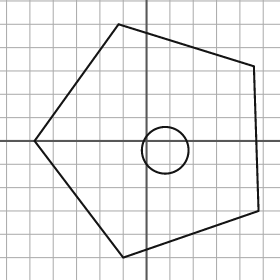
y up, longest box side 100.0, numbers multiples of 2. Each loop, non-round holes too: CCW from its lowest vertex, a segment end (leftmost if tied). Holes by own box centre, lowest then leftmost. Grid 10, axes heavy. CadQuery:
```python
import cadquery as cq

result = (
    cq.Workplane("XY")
    .moveTo(-10.0, -50.0)
    .lineTo(48.0, -30.0)
    .lineTo(46.0, 32.0)
    .lineTo(-12.0, 50.0)
    .lineTo(-48.0, 0.0)
    .close()
    .moveTo(8.0, -4.0)
    .circle(10.0)
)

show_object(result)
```